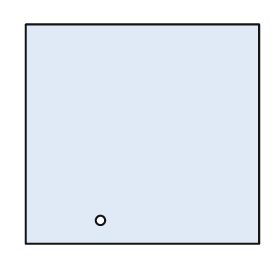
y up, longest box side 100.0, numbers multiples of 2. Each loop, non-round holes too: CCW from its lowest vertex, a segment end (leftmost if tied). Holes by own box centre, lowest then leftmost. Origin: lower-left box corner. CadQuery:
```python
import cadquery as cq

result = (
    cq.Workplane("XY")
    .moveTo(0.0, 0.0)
    .lineTo(100.0, 0.0)
    .lineTo(100.0, 94.0)
    .lineTo(0.0, 94.0)
    .close()
    .moveTo(32.0, 10.0)
    .circle(2.0)
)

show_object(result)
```